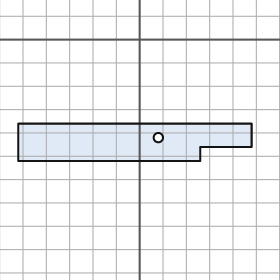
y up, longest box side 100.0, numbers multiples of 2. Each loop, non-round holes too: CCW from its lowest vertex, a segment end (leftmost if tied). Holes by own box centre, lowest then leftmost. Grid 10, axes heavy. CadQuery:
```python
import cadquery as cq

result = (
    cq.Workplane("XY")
    .moveTo(-52.0, -52.0)
    .lineTo(26.0, -52.0)
    .lineTo(26.0, -46.0)
    .lineTo(48.0, -46.0)
    .lineTo(48.0, -36.0)
    .lineTo(-52.0, -36.0)
    .close()
    .moveTo(8.0, -42.0)
    .circle(2.0)
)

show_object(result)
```